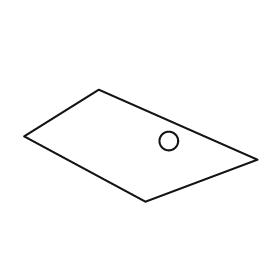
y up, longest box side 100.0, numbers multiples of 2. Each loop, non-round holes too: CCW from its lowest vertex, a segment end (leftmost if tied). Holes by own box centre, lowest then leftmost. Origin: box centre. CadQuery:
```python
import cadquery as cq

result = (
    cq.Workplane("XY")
    .moveTo(2.0, -24.0)
    .lineTo(50.0, -6.0)
    .lineTo(-18.0, 24.0)
    .lineTo(-50.0, 4.0)
    .close()
    .moveTo(12.0, 2.0)
    .circle(4.0)
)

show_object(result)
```